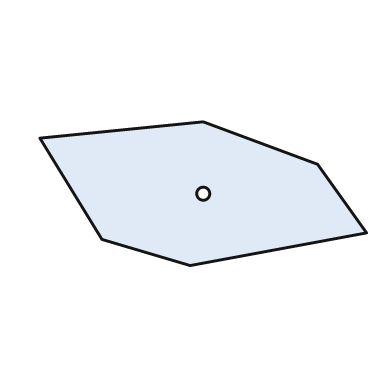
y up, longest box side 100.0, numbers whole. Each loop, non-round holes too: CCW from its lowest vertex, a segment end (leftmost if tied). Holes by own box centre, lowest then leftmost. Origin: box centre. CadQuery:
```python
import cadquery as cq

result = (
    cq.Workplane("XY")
    .moveTo(-4.0, -22.0)
    .lineTo(50.0, -12.0)
    .lineTo(35.0, 9.0)
    .lineTo(0.0, 22.0)
    .lineTo(-50.0, 17.0)
    .lineTo(-31.0, -14.0)
    .close()
    .moveTo(0.0, 0.0)
    .circle(2.0)
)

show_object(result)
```